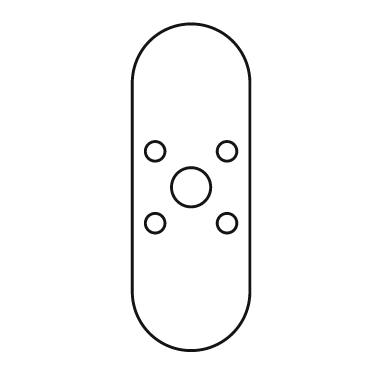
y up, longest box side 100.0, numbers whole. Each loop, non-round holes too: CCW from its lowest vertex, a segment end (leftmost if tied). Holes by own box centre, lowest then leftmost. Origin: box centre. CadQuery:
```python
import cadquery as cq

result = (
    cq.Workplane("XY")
    .moveTo(-18.0, -32.0)
    .threePointArc((0.0, -50.0), (18.0, -32.0))
    .lineTo(18.0, 32.0)
    .threePointArc((0.0, 50.0), (-18.0, 32.0))
    .close()
    .moveTo(-11.0, -11.0)
    .circle(3.0)
    .moveTo(11.0, -11.0)
    .circle(3.0)
    .moveTo(0.0, 0.0)
    .circle(6.0)
    .moveTo(-11.0, 11.0)
    .circle(3.0)
    .moveTo(11.0, 11.0)
    .circle(3.0)
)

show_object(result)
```